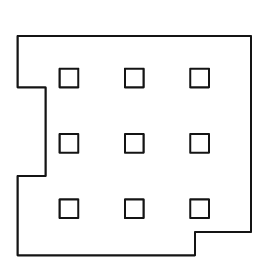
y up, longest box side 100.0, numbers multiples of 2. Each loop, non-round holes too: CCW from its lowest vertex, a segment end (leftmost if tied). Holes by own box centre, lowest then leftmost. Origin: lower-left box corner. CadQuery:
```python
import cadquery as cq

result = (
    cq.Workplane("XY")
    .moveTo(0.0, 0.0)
    .lineTo(76.0, 0.0)
    .lineTo(76.0, 10.0)
    .lineTo(100.0, 10.0)
    .lineTo(100.0, 94.0)
    .lineTo(0.0, 94.0)
    .lineTo(0.0, 72.0)
    .lineTo(12.0, 72.0)
    .lineTo(12.0, 34.0)
    .lineTo(0.0, 34.0)
    .close()
    .moveTo(18.0, 16.0)
    .lineTo(26.0, 16.0)
    .lineTo(26.0, 24.0)
    .lineTo(18.0, 24.0)
    .close()
    .moveTo(46.0, 16.0)
    .lineTo(54.0, 16.0)
    .lineTo(54.0, 24.0)
    .lineTo(46.0, 24.0)
    .close()
    .moveTo(74.0, 16.0)
    .lineTo(82.0, 16.0)
    .lineTo(82.0, 24.0)
    .lineTo(74.0, 24.0)
    .close()
    .moveTo(18.0, 44.0)
    .lineTo(26.0, 44.0)
    .lineTo(26.0, 52.0)
    .lineTo(18.0, 52.0)
    .close()
    .moveTo(46.0, 44.0)
    .lineTo(54.0, 44.0)
    .lineTo(54.0, 52.0)
    .lineTo(46.0, 52.0)
    .close()
    .moveTo(74.0, 44.0)
    .lineTo(82.0, 44.0)
    .lineTo(82.0, 52.0)
    .lineTo(74.0, 52.0)
    .close()
    .moveTo(18.0, 72.0)
    .lineTo(26.0, 72.0)
    .lineTo(26.0, 80.0)
    .lineTo(18.0, 80.0)
    .close()
    .moveTo(46.0, 72.0)
    .lineTo(54.0, 72.0)
    .lineTo(54.0, 80.0)
    .lineTo(46.0, 80.0)
    .close()
    .moveTo(74.0, 72.0)
    .lineTo(82.0, 72.0)
    .lineTo(82.0, 80.0)
    .lineTo(74.0, 80.0)
    .close()
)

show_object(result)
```